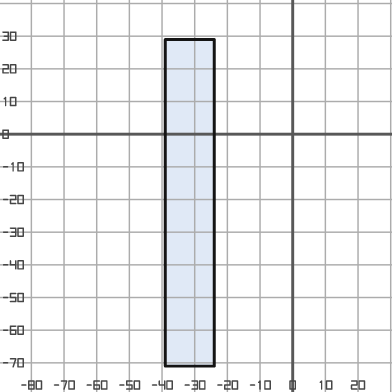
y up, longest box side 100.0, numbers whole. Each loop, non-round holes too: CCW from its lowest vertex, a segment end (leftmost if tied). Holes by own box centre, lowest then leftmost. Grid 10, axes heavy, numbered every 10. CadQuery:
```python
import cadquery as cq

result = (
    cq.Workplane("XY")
    .moveTo(-39.0, -71.0)
    .lineTo(-24.0, -71.0)
    .lineTo(-24.0, 29.0)
    .lineTo(-39.0, 29.0)
    .close()
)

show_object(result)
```